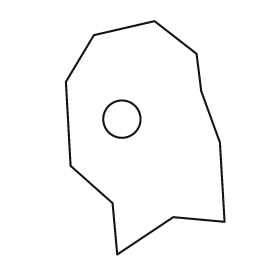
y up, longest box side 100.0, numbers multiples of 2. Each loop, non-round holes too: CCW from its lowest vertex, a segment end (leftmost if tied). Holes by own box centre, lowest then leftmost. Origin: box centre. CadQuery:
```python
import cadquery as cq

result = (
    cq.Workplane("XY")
    .moveTo(-12.0, -50.0)
    .lineTo(12.0, -34.0)
    .lineTo(34.0, -36.0)
    .lineTo(32.0, -2.0)
    .lineTo(24.0, 20.0)
    .lineTo(22.0, 36.0)
    .lineTo(4.0, 50.0)
    .lineTo(-22.0, 44.0)
    .lineTo(-34.0, 24.0)
    .lineTo(-32.0, -12.0)
    .lineTo(-14.0, -28.0)
    .close()
    .moveTo(-10.0, 8.0)
    .circle(8.0)
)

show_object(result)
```